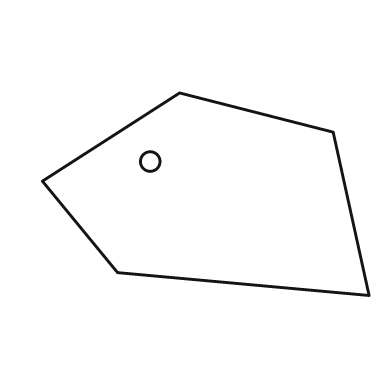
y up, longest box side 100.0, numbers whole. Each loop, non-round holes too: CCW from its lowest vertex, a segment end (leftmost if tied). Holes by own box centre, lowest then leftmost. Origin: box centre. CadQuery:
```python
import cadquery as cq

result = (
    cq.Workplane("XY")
    .moveTo(50.0, -31.0)
    .lineTo(39.0, 19.0)
    .lineTo(-8.0, 31.0)
    .lineTo(-50.0, 4.0)
    .lineTo(-27.0, -24.0)
    .close()
    .moveTo(-17.0, 10.0)
    .circle(3.0)
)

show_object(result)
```